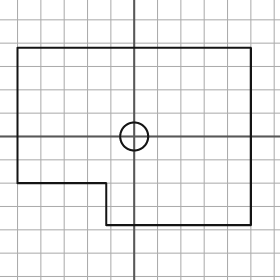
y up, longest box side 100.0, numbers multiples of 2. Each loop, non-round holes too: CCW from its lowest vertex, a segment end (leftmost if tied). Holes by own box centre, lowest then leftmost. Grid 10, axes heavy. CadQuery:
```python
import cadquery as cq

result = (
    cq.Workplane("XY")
    .moveTo(-12.0, -38.0)
    .lineTo(50.0, -38.0)
    .lineTo(50.0, 38.0)
    .lineTo(-50.0, 38.0)
    .lineTo(-50.0, -20.0)
    .lineTo(-12.0, -20.0)
    .close()
    .moveTo(0.0, 0.0)
    .circle(6.0)
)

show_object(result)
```